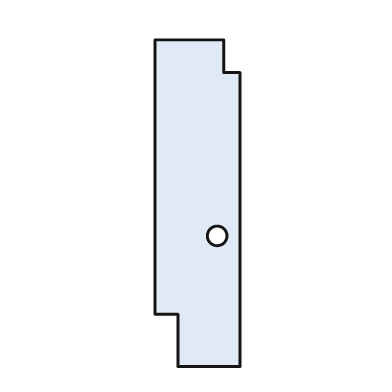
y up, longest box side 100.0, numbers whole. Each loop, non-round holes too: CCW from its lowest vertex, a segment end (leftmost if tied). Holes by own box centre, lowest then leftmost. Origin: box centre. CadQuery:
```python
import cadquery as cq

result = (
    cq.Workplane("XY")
    .moveTo(-6.0, -50.0)
    .lineTo(13.0, -50.0)
    .lineTo(13.0, 40.0)
    .lineTo(8.0, 40.0)
    .lineTo(8.0, 50.0)
    .lineTo(-13.0, 50.0)
    .lineTo(-13.0, -34.0)
    .lineTo(-6.0, -34.0)
    .close()
    .moveTo(6.0, -10.0)
    .circle(3.0)
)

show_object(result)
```